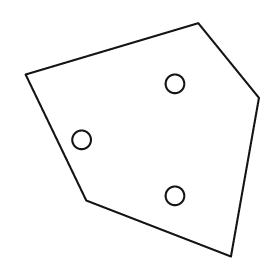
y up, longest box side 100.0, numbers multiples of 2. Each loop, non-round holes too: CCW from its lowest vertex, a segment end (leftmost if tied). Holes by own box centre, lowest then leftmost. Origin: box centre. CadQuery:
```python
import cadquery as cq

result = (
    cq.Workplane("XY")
    .moveTo(38.0, -50.0)
    .lineTo(50.0, 18.0)
    .lineTo(24.0, 50.0)
    .lineTo(-50.0, 28.0)
    .lineTo(-24.0, -26.0)
    .close()
    .moveTo(14.0, -24.0)
    .circle(4.0)
    .moveTo(-26.0, 0.0)
    .circle(4.0)
    .moveTo(14.0, 24.0)
    .circle(4.0)
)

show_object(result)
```